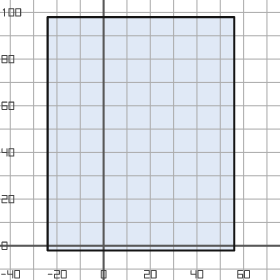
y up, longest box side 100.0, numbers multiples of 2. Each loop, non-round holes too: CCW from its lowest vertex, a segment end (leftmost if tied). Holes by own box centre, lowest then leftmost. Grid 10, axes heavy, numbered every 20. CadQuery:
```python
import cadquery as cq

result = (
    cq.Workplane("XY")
    .moveTo(-24.0, -2.0)
    .lineTo(56.0, -2.0)
    .lineTo(56.0, 98.0)
    .lineTo(-24.0, 98.0)
    .close()
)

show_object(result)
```